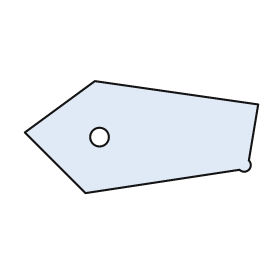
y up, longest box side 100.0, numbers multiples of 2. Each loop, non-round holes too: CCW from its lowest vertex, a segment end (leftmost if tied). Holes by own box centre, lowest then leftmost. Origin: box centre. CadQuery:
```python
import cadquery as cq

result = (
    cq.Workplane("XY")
    .moveTo(-24.0, -24.0)
    .lineTo(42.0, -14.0)
    .threePointArc((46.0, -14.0), (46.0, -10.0))
    .lineTo(50.0, 14.0)
    .lineTo(-20.0, 24.0)
    .lineTo(-50.0, 2.0)
    .close()
    .moveTo(-18.0, 0.0)
    .circle(4.0)
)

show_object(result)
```